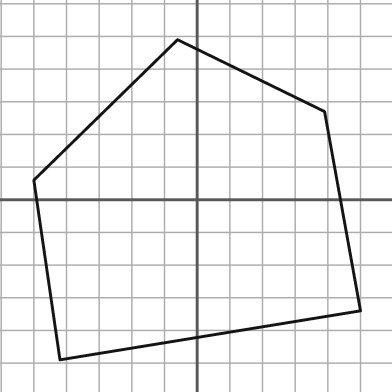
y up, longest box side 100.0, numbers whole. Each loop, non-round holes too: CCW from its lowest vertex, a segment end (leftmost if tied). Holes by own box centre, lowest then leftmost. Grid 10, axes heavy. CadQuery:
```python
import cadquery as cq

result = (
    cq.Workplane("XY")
    .moveTo(-42.0, -49.0)
    .lineTo(50.0, -34.0)
    .lineTo(39.0, 27.0)
    .lineTo(-6.0, 49.0)
    .lineTo(-50.0, 6.0)
    .close()
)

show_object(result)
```